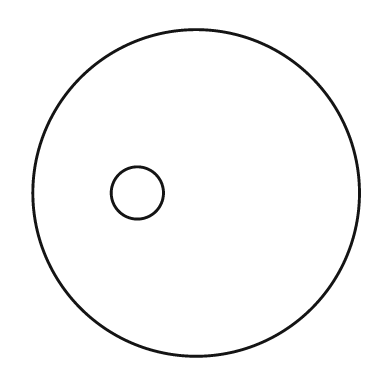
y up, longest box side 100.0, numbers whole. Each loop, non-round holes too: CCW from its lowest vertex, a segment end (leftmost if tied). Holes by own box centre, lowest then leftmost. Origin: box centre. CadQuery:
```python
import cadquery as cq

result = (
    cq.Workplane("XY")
    .moveTo(0.0, 0.0)
    .circle(50.0)
    .moveTo(-18.0, 0.0)
    .circle(8.0)
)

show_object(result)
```